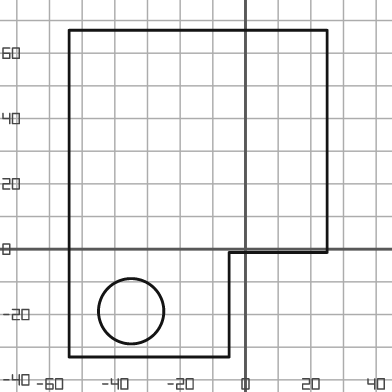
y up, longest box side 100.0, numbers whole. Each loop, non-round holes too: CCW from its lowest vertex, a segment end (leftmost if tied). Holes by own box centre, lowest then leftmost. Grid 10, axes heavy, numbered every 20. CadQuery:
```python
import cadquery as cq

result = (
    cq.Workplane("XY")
    .moveTo(-54.0, -33.0)
    .lineTo(-5.0, -33.0)
    .lineTo(-5.0, -1.0)
    .lineTo(25.0, -1.0)
    .lineTo(25.0, 67.0)
    .lineTo(-54.0, 67.0)
    .close()
    .moveTo(-35.0, -19.0)
    .circle(10.0)
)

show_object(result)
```